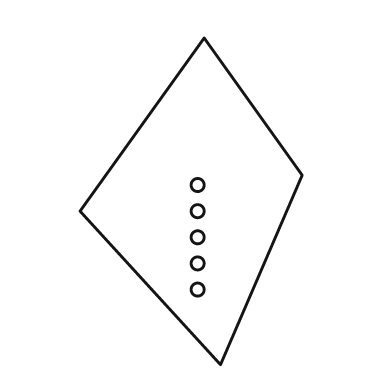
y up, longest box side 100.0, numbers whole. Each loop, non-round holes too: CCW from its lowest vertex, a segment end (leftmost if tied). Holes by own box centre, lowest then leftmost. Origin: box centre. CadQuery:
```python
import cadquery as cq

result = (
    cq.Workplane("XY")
    .moveTo(9.0, -50.0)
    .lineTo(34.0, 8.0)
    .lineTo(4.0, 50.0)
    .lineTo(-34.0, -3.0)
    .close()
    .moveTo(2.0, -27.0)
    .circle(2.0)
    .moveTo(2.0, -19.0)
    .circle(2.0)
    .moveTo(2.0, -11.0)
    .circle(2.0)
    .moveTo(2.0, -3.0)
    .circle(2.0)
    .moveTo(2.0, 5.0)
    .circle(2.0)
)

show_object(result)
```